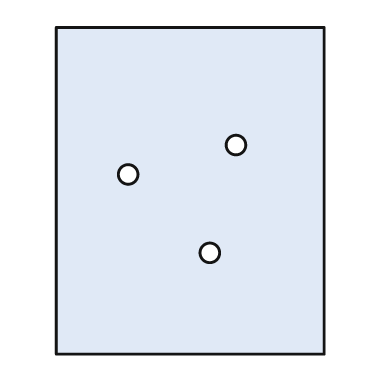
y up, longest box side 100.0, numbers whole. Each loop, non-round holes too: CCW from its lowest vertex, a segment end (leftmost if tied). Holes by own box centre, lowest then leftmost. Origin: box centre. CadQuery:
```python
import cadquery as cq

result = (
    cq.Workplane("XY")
    .moveTo(-41.0, -50.0)
    .lineTo(41.0, -50.0)
    .lineTo(41.0, 50.0)
    .lineTo(-41.0, 50.0)
    .close()
    .moveTo(6.0, -19.0)
    .circle(3.0)
    .moveTo(-19.0, 5.0)
    .circle(3.0)
    .moveTo(14.0, 14.0)
    .circle(3.0)
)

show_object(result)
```